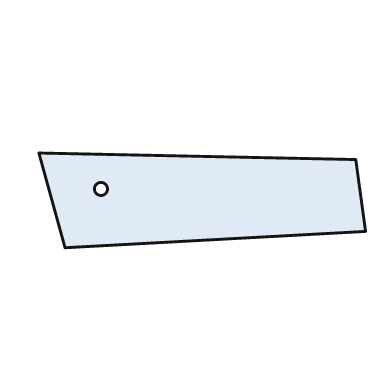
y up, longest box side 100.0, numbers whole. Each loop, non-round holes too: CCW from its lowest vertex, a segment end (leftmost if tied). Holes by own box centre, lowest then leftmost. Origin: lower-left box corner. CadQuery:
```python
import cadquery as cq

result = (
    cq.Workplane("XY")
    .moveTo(8.0, 0.0)
    .lineTo(100.0, 5.0)
    .lineTo(97.0, 27.0)
    .lineTo(0.0, 29.0)
    .close()
    .moveTo(19.0, 18.0)
    .circle(2.0)
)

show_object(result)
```